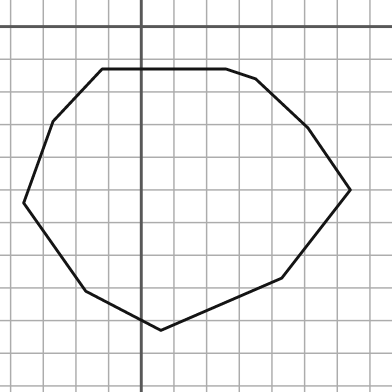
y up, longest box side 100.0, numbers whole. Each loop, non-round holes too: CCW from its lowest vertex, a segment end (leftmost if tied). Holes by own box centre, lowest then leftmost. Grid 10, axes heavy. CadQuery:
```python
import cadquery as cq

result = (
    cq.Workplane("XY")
    .moveTo(6.0, -93.0)
    .lineTo(43.0, -77.0)
    .lineTo(64.0, -50.0)
    .lineTo(51.0, -31.0)
    .lineTo(35.0, -16.0)
    .lineTo(26.0, -13.0)
    .lineTo(-12.0, -13.0)
    .lineTo(-27.0, -29.0)
    .lineTo(-36.0, -54.0)
    .lineTo(-17.0, -81.0)
    .close()
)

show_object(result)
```